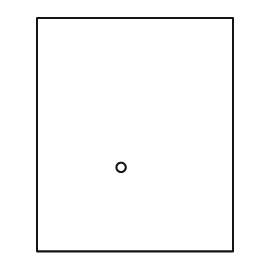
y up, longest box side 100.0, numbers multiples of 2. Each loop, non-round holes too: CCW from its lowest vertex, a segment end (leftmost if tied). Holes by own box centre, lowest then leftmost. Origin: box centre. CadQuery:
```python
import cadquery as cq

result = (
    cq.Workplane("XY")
    .moveTo(-42.0, -50.0)
    .lineTo(42.0, -50.0)
    .lineTo(42.0, 50.0)
    .lineTo(-42.0, 50.0)
    .close()
    .moveTo(-6.0, -14.0)
    .circle(2.0)
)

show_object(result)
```